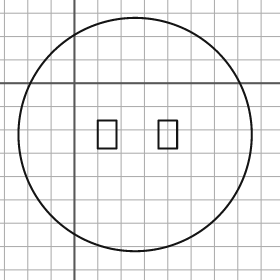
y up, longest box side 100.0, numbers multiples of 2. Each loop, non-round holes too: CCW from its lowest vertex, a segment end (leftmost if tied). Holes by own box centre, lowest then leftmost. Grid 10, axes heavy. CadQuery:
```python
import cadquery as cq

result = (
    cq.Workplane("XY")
    .moveTo(26.0, -22.0)
    .circle(50.0)
    .moveTo(10.0, -28.0)
    .lineTo(18.0, -28.0)
    .lineTo(18.0, -16.0)
    .lineTo(10.0, -16.0)
    .close()
    .moveTo(36.0, -28.0)
    .lineTo(44.0, -28.0)
    .lineTo(44.0, -16.0)
    .lineTo(36.0, -16.0)
    .close()
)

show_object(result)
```